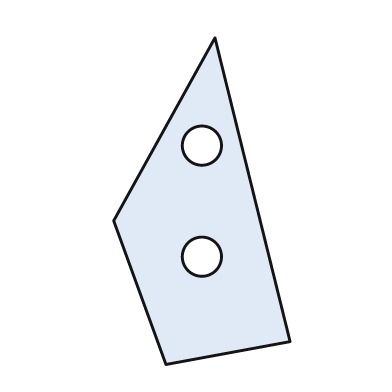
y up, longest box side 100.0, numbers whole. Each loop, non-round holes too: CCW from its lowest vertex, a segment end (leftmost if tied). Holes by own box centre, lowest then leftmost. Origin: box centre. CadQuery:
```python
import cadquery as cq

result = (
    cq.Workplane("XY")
    .moveTo(-11.0, -50.0)
    .lineTo(27.0, -43.0)
    .lineTo(4.0, 50.0)
    .lineTo(-27.0, -6.0)
    .close()
    .moveTo(0.0, -17.0)
    .circle(6.0)
    .moveTo(0.0, 17.0)
    .circle(6.0)
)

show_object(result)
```